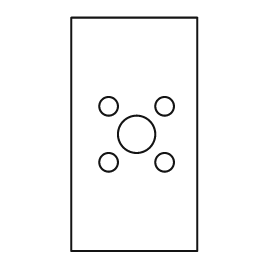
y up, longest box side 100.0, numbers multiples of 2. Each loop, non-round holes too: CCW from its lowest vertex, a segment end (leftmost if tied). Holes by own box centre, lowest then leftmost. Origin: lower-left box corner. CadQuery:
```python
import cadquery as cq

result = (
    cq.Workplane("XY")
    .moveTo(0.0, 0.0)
    .lineTo(54.0, 0.0)
    .lineTo(54.0, 100.0)
    .lineTo(0.0, 100.0)
    .close()
    .moveTo(16.0, 38.0)
    .circle(4.0)
    .moveTo(40.0, 38.0)
    .circle(4.0)
    .moveTo(28.0, 50.0)
    .circle(8.0)
    .moveTo(16.0, 62.0)
    .circle(4.0)
    .moveTo(40.0, 62.0)
    .circle(4.0)
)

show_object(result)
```